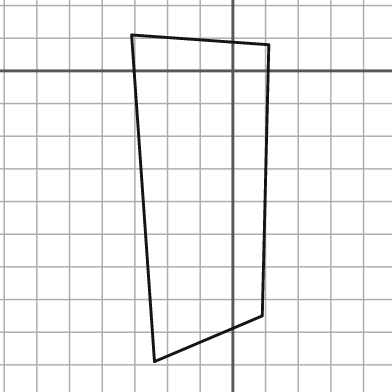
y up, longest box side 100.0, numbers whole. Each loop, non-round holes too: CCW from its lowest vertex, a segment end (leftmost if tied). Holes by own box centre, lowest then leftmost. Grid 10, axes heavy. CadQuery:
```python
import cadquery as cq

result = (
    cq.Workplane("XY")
    .moveTo(-24.0, -89.0)
    .lineTo(9.0, -75.0)
    .lineTo(11.0, 8.0)
    .lineTo(-31.0, 11.0)
    .close()
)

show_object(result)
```